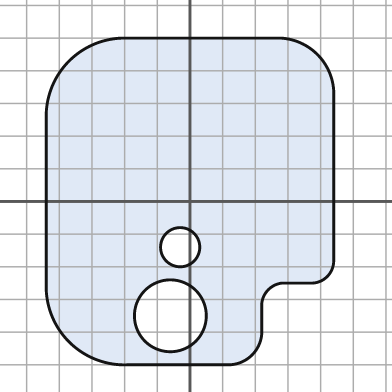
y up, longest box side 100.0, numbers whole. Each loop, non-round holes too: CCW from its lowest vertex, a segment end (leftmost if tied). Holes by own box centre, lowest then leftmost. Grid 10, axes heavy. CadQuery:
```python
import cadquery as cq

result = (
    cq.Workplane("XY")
    .moveTo(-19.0, -50.0)
    .lineTo(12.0, -50.0)
    .threePointArc((19.0, -47.0), (22.0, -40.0))
    .lineTo(22.0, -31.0)
    .threePointArc((24.0, -27.0), (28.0, -25.0))
    .lineTo(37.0, -25.0)
    .threePointArc((42.0, -23.0), (44.0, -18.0))
    .lineTo(44.0, 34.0)
    .threePointArc((39.0, 45.0), (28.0, 50.0))
    .lineTo(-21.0, 50.0)
    .threePointArc((-37.0, 43.0), (-44.0, 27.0))
    .lineTo(-44.0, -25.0)
    .threePointArc((-37.0, -43.0), (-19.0, -50.0))
    .close()
    .moveTo(-6.0, -35.0)
    .circle(11.0)
    .moveTo(-3.0, -14.0)
    .circle(6.0)
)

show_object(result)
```